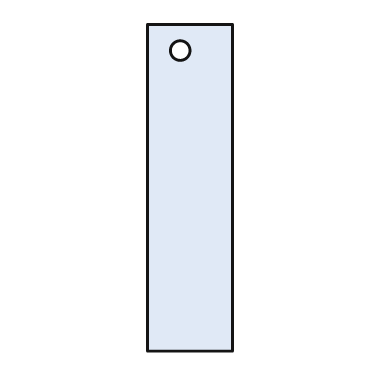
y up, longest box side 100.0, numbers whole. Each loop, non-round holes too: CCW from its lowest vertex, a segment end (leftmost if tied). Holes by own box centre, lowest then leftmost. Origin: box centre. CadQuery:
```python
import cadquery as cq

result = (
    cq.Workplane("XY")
    .moveTo(-13.0, -50.0)
    .lineTo(13.0, -50.0)
    .lineTo(13.0, 50.0)
    .lineTo(-13.0, 50.0)
    .close()
    .moveTo(-3.0, 42.0)
    .circle(3.0)
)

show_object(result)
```